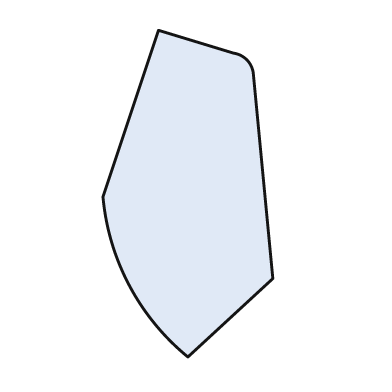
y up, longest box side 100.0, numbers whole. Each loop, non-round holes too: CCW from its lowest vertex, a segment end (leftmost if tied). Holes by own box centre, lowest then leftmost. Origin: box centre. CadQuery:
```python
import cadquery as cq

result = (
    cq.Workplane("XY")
    .moveTo(0.0, -50.0)
    .lineTo(26.0, -26.0)
    .lineTo(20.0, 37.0)
    .threePointArc((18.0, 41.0), (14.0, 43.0))
    .lineTo(-9.0, 50.0)
    .lineTo(-26.0, -1.0)
    .threePointArc((-18.0, -28.0), (0.0, -50.0))
    .close()
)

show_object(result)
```